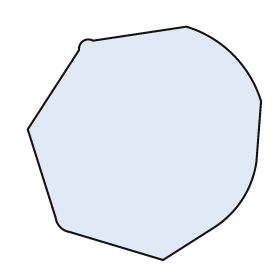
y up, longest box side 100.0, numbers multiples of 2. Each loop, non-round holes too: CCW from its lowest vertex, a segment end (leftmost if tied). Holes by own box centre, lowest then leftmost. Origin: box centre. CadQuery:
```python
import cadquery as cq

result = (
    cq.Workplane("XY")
    .moveTo(8.0, -50.0)
    .lineTo(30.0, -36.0)
    .threePointArc((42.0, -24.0), (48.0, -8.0))
    .lineTo(50.0, 18.0)
    .threePointArc((38.0, 38.0), (18.0, 50.0))
    .lineTo(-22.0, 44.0)
    .threePointArc((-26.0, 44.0), (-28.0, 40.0))
    .lineTo(-50.0, 6.0)
    .lineTo(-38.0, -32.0)
    .threePointArc((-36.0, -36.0), (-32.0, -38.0))
    .close()
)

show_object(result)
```